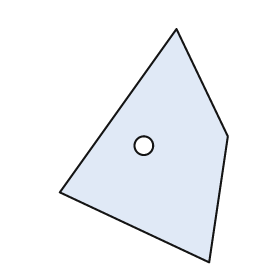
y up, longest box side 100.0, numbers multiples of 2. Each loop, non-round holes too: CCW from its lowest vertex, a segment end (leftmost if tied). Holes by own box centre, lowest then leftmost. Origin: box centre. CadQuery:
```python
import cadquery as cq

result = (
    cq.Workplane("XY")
    .moveTo(28.0, -50.0)
    .lineTo(36.0, 4.0)
    .lineTo(14.0, 50.0)
    .lineTo(-36.0, -20.0)
    .close()
    .moveTo(0.0, 0.0)
    .circle(4.0)
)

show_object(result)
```